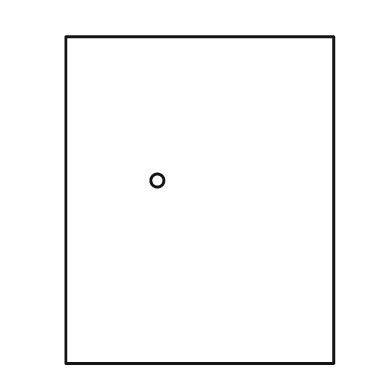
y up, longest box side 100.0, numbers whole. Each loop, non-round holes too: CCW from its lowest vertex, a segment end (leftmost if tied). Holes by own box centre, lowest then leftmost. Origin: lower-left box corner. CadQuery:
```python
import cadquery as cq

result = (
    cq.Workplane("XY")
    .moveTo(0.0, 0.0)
    .lineTo(82.0, 0.0)
    .lineTo(82.0, 100.0)
    .lineTo(0.0, 100.0)
    .close()
    .moveTo(28.0, 56.0)
    .circle(2.0)
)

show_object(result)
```